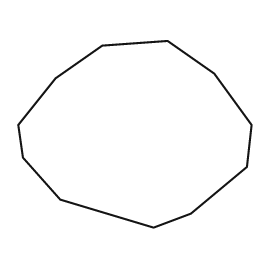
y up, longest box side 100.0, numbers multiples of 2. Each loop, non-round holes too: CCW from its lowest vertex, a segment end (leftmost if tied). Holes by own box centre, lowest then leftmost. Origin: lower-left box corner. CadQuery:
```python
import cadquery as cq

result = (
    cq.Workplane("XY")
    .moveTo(58.0, 0.0)
    .lineTo(74.0, 6.0)
    .lineTo(98.0, 26.0)
    .lineTo(100.0, 44.0)
    .lineTo(84.0, 66.0)
    .lineTo(64.0, 80.0)
    .lineTo(36.0, 78.0)
    .lineTo(16.0, 64.0)
    .lineTo(0.0, 44.0)
    .lineTo(2.0, 30.0)
    .lineTo(18.0, 12.0)
    .close()
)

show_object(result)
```